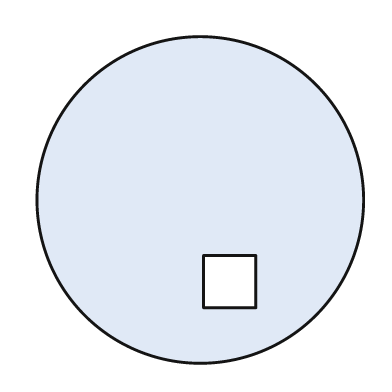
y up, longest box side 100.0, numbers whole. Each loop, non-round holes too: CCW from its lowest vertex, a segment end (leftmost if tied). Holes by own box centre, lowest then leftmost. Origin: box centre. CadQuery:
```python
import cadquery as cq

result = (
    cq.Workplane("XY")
    .moveTo(0.0, 0.0)
    .circle(50.0)
    .moveTo(1.0, -33.0)
    .lineTo(17.0, -33.0)
    .lineTo(17.0, -17.0)
    .lineTo(1.0, -17.0)
    .close()
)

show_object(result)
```